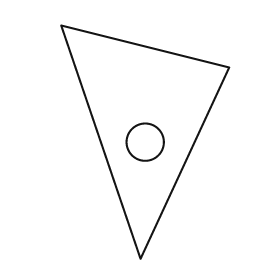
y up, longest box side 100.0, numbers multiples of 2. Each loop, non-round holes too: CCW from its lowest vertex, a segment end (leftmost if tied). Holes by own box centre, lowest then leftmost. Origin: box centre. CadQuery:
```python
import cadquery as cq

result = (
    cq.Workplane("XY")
    .moveTo(-2.0, -50.0)
    .lineTo(36.0, 32.0)
    .lineTo(-36.0, 50.0)
    .close()
    .moveTo(0.0, 0.0)
    .circle(8.0)
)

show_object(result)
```